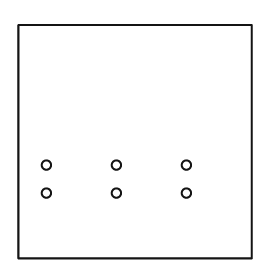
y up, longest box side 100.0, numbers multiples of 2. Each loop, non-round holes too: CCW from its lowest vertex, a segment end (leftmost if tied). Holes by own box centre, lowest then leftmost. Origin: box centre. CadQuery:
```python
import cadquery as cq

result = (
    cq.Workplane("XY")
    .moveTo(-50.0, -50.0)
    .lineTo(50.0, -50.0)
    .lineTo(50.0, 50.0)
    .lineTo(-50.0, 50.0)
    .close()
    .moveTo(-38.0, -22.0)
    .circle(2.0)
    .moveTo(-8.0, -22.0)
    .circle(2.0)
    .moveTo(22.0, -22.0)
    .circle(2.0)
    .moveTo(-38.0, -10.0)
    .circle(2.0)
    .moveTo(-8.0, -10.0)
    .circle(2.0)
    .moveTo(22.0, -10.0)
    .circle(2.0)
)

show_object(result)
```